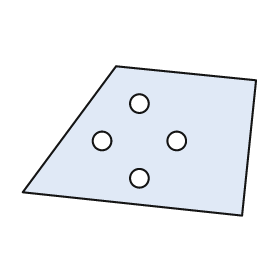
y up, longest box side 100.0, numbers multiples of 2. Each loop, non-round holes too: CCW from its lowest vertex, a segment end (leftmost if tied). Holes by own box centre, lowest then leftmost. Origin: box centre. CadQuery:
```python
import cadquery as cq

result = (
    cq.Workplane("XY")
    .moveTo(44.0, -32.0)
    .lineTo(50.0, 26.0)
    .lineTo(-10.0, 32.0)
    .lineTo(-50.0, -22.0)
    .close()
    .moveTo(0.0, -16.0)
    .circle(4.0)
    .moveTo(-16.0, 0.0)
    .circle(4.0)
    .moveTo(16.0, 0.0)
    .circle(4.0)
    .moveTo(0.0, 16.0)
    .circle(4.0)
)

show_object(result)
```